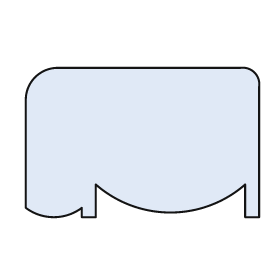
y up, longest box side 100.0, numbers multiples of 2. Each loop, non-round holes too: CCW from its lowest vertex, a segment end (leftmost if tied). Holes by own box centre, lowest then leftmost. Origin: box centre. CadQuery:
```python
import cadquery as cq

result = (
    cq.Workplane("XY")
    .moveTo(-26.0, -32.0)
    .lineTo(-20.0, -32.0)
    .lineTo(-20.0, -18.0)
    .threePointArc((12.0, -30.0), (44.0, -18.0))
    .lineTo(44.0, -32.0)
    .lineTo(50.0, -32.0)
    .lineTo(50.0, 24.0)
    .threePointArc((48.0, 30.0), (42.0, 32.0))
    .lineTo(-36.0, 32.0)
    .threePointArc((-46.0, 28.0), (-50.0, 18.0))
    .lineTo(-50.0, -28.0)
    .threePointArc((-38.0, -32.0), (-26.0, -28.0))
    .close()
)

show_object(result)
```